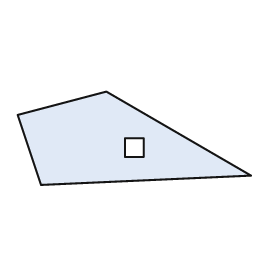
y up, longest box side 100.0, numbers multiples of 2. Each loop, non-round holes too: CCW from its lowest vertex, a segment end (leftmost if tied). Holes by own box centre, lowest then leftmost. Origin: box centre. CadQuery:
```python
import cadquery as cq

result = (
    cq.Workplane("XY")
    .moveTo(-40.0, -20.0)
    .lineTo(50.0, -16.0)
    .lineTo(-12.0, 20.0)
    .lineTo(-50.0, 10.0)
    .close()
    .moveTo(-4.0, -8.0)
    .lineTo(4.0, -8.0)
    .lineTo(4.0, 0.0)
    .lineTo(-4.0, 0.0)
    .close()
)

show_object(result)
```